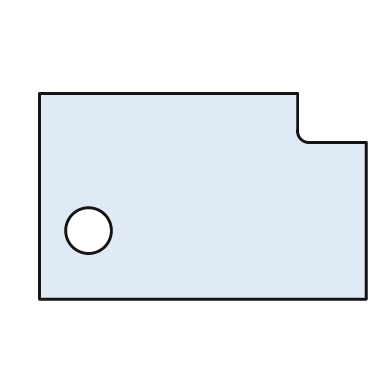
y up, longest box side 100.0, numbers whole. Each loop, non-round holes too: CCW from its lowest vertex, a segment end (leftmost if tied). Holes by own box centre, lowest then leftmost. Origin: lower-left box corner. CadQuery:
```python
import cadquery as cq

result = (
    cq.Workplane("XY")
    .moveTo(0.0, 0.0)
    .lineTo(100.0, 0.0)
    .lineTo(100.0, 48.0)
    .lineTo(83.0, 48.0)
    .threePointArc((80.0, 49.0), (79.0, 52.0))
    .lineTo(79.0, 63.0)
    .lineTo(0.0, 63.0)
    .close()
    .moveTo(15.0, 21.0)
    .circle(7.0)
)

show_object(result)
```